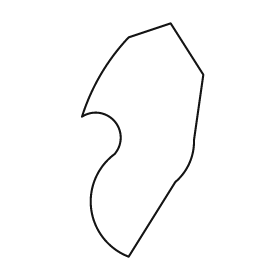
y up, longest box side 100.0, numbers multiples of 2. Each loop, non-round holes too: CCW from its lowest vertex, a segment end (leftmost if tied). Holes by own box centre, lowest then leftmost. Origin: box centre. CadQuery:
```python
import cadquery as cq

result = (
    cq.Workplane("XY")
    .moveTo(-6.0, -50.0)
    .lineTo(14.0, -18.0)
    .threePointArc((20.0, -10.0), (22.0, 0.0))
    .lineTo(26.0, 28.0)
    .lineTo(12.0, 50.0)
    .lineTo(-6.0, 44.0)
    .threePointArc((-18.0, 28.0), (-26.0, 10.0))
    .threePointArc((-12.0, 8.0), (-12.0, -6.0))
    .threePointArc((-22.0, -30.0), (-6.0, -50.0))
    .close()
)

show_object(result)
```